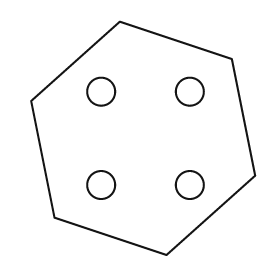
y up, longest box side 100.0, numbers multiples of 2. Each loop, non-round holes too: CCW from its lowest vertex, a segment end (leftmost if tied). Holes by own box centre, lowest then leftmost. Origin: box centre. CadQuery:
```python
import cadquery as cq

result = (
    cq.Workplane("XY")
    .moveTo(10.0, -50.0)
    .lineTo(48.0, -16.0)
    .lineTo(38.0, 34.0)
    .lineTo(-10.0, 50.0)
    .lineTo(-48.0, 16.0)
    .lineTo(-38.0, -34.0)
    .close()
    .moveTo(-18.0, -20.0)
    .circle(6.0)
    .moveTo(20.0, -20.0)
    .circle(6.0)
    .moveTo(-18.0, 20.0)
    .circle(6.0)
    .moveTo(20.0, 20.0)
    .circle(6.0)
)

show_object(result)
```